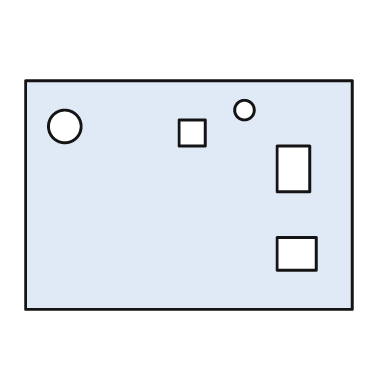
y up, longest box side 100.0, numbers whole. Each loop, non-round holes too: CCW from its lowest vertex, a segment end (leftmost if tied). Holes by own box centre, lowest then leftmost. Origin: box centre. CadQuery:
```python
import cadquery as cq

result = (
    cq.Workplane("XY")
    .moveTo(-50.0, -35.0)
    .lineTo(50.0, -35.0)
    .lineTo(50.0, 35.0)
    .lineTo(-50.0, 35.0)
    .close()
    .moveTo(27.0, -23.0)
    .lineTo(39.0, -23.0)
    .lineTo(39.0, -13.0)
    .lineTo(27.0, -13.0)
    .close()
    .moveTo(27.0, 1.0)
    .lineTo(37.0, 1.0)
    .lineTo(37.0, 15.0)
    .lineTo(27.0, 15.0)
    .close()
    .moveTo(-3.0, 15.0)
    .lineTo(5.0, 15.0)
    .lineTo(5.0, 23.0)
    .lineTo(-3.0, 23.0)
    .close()
    .moveTo(-38.0, 21.0)
    .circle(5.0)
    .moveTo(17.0, 26.0)
    .circle(3.0)
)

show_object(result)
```